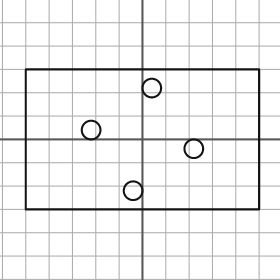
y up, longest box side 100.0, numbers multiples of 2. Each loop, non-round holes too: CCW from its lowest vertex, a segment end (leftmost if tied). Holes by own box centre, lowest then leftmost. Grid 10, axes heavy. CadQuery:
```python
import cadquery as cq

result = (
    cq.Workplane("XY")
    .moveTo(-50.0, -30.0)
    .lineTo(50.0, -30.0)
    .lineTo(50.0, 30.0)
    .lineTo(-50.0, 30.0)
    .close()
    .moveTo(-4.0, -22.0)
    .circle(4.0)
    .moveTo(22.0, -4.0)
    .circle(4.0)
    .moveTo(-22.0, 4.0)
    .circle(4.0)
    .moveTo(4.0, 22.0)
    .circle(4.0)
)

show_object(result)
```